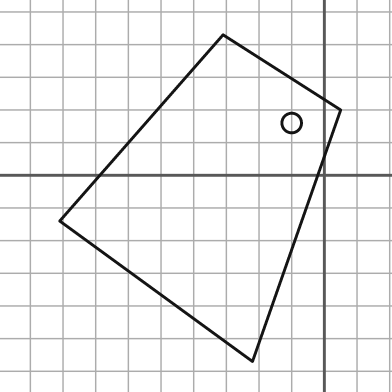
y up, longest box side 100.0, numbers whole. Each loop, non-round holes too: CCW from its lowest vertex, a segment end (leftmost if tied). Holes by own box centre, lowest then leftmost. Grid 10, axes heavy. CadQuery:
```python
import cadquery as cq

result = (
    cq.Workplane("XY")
    .moveTo(-22.0, -57.0)
    .lineTo(5.0, 20.0)
    .lineTo(-31.0, 43.0)
    .lineTo(-81.0, -14.0)
    .close()
    .moveTo(-10.0, 16.0)
    .circle(3.0)
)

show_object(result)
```